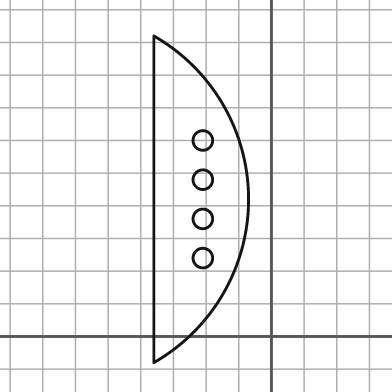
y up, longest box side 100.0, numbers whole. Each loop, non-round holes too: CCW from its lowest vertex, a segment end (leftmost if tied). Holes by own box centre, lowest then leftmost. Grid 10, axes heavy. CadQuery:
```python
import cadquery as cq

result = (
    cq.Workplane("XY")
    .moveTo(-36.0, -8.0)
    .threePointArc((-7.0, 42.0), (-36.0, 92.0))
    .close()
    .moveTo(-21.0, 24.0)
    .circle(3.0)
    .moveTo(-21.0, 36.0)
    .circle(3.0)
    .moveTo(-21.0, 48.0)
    .circle(3.0)
    .moveTo(-21.0, 60.0)
    .circle(3.0)
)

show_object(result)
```